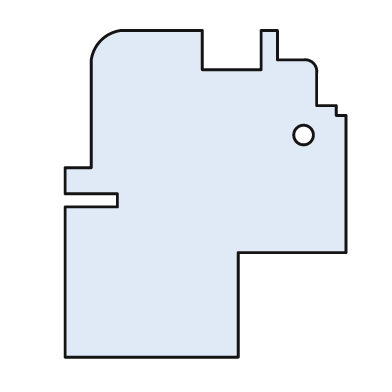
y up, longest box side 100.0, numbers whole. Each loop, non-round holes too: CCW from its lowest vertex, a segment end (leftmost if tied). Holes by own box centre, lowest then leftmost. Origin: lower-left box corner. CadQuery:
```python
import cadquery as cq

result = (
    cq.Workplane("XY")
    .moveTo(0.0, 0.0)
    .lineTo(53.0, 0.0)
    .lineTo(53.0, 32.0)
    .lineTo(86.0, 32.0)
    .lineTo(86.0, 74.0)
    .lineTo(83.0, 74.0)
    .lineTo(83.0, 77.0)
    .lineTo(77.0, 77.0)
    .lineTo(77.0, 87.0)
    .threePointArc((76.0, 90.0), (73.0, 91.0))
    .lineTo(65.0, 91.0)
    .lineTo(65.0, 100.0)
    .lineTo(60.0, 100.0)
    .lineTo(60.0, 88.0)
    .lineTo(42.0, 88.0)
    .lineTo(42.0, 100.0)
    .lineTo(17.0, 100.0)
    .threePointArc((11.0, 97.0), (8.0, 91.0))
    .lineTo(8.0, 58.0)
    .lineTo(0.0, 58.0)
    .lineTo(0.0, 50.0)
    .lineTo(16.0, 50.0)
    .lineTo(16.0, 46.0)
    .lineTo(0.0, 46.0)
    .close()
    .moveTo(73.0, 68.0)
    .circle(3.0)
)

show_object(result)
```